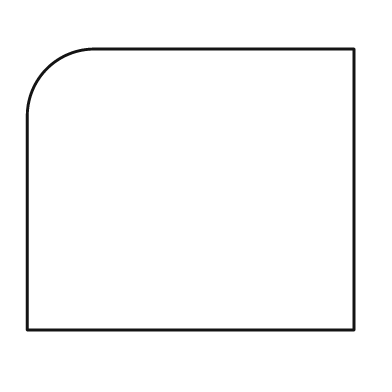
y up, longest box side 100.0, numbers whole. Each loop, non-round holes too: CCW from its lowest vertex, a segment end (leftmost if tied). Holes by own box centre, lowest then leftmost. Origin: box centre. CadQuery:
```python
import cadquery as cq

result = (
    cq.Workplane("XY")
    .moveTo(-50.0, -43.0)
    .lineTo(50.0, -43.0)
    .lineTo(50.0, 43.0)
    .lineTo(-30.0, 43.0)
    .threePointArc((-44.0, 37.0), (-50.0, 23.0))
    .close()
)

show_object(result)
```